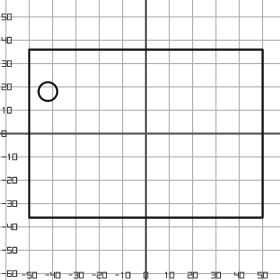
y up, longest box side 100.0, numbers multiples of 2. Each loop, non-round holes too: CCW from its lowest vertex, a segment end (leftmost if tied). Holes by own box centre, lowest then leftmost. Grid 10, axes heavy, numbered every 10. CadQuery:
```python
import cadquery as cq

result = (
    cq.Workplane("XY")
    .moveTo(-50.0, -36.0)
    .lineTo(50.0, -36.0)
    .lineTo(50.0, 36.0)
    .lineTo(-50.0, 36.0)
    .close()
    .moveTo(-42.0, 18.0)
    .circle(4.0)
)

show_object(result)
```